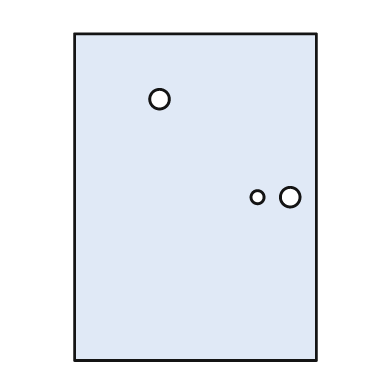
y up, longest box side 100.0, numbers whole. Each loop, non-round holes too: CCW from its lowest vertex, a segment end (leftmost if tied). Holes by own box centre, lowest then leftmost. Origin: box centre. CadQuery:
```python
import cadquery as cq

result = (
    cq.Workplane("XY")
    .moveTo(-37.0, -50.0)
    .lineTo(37.0, -50.0)
    .lineTo(37.0, 50.0)
    .lineTo(-37.0, 50.0)
    .close()
    .moveTo(19.0, 0.0)
    .circle(2.0)
    .moveTo(29.0, 0.0)
    .circle(3.0)
    .moveTo(-11.0, 30.0)
    .circle(3.0)
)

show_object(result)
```